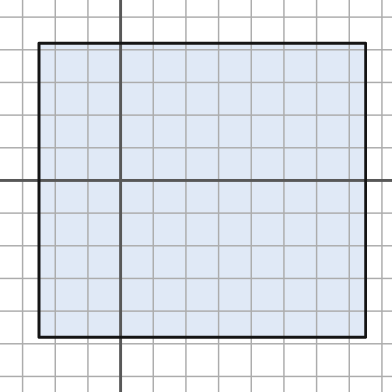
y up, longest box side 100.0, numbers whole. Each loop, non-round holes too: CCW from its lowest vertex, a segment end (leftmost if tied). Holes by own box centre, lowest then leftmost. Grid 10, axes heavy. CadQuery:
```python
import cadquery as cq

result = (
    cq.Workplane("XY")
    .moveTo(-25.0, -48.0)
    .lineTo(75.0, -48.0)
    .lineTo(75.0, 42.0)
    .lineTo(-25.0, 42.0)
    .close()
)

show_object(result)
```